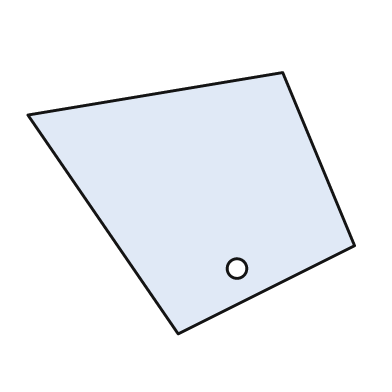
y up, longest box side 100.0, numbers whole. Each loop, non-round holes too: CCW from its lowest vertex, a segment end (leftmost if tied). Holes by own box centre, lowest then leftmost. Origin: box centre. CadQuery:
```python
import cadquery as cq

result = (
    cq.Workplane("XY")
    .moveTo(-4.0, -40.0)
    .lineTo(50.0, -13.0)
    .lineTo(28.0, 40.0)
    .lineTo(-50.0, 27.0)
    .close()
    .moveTo(14.0, -20.0)
    .circle(3.0)
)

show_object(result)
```